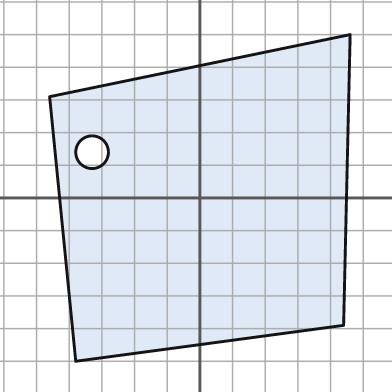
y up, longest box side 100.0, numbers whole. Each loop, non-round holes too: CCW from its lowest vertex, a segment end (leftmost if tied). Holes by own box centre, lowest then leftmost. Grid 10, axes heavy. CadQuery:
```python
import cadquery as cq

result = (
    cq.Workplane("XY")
    .moveTo(-38.0, -50.0)
    .lineTo(44.0, -39.0)
    .lineTo(46.0, 50.0)
    .lineTo(-46.0, 31.0)
    .close()
    .moveTo(-33.0, 14.0)
    .circle(5.0)
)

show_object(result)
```